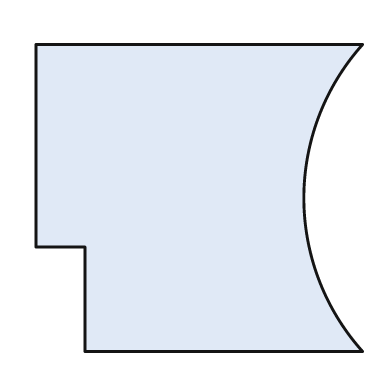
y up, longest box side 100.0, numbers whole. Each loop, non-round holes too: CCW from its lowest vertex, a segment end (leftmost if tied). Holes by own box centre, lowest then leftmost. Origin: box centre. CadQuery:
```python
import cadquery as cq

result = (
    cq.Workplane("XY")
    .moveTo(-35.0, -47.0)
    .lineTo(50.0, -47.0)
    .threePointArc((32.0, 0.0), (50.0, 47.0))
    .lineTo(-50.0, 47.0)
    .lineTo(-50.0, -15.0)
    .lineTo(-35.0, -15.0)
    .close()
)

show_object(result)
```